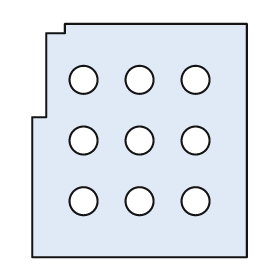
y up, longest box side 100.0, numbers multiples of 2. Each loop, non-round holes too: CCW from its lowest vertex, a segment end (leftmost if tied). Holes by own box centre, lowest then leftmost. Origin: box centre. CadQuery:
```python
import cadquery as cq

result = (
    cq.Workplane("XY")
    .moveTo(-46.0, -50.0)
    .lineTo(46.0, -50.0)
    .lineTo(46.0, 50.0)
    .lineTo(-32.0, 50.0)
    .lineTo(-32.0, 46.0)
    .lineTo(-40.0, 46.0)
    .lineTo(-40.0, 10.0)
    .lineTo(-46.0, 10.0)
    .close()
    .moveTo(-24.0, -26.0)
    .circle(6.0)
    .moveTo(0.0, -26.0)
    .circle(6.0)
    .moveTo(24.0, -26.0)
    .circle(6.0)
    .moveTo(-24.0, 0.0)
    .circle(6.0)
    .moveTo(0.0, 0.0)
    .circle(6.0)
    .moveTo(24.0, 0.0)
    .circle(6.0)
    .moveTo(-24.0, 26.0)
    .circle(6.0)
    .moveTo(0.0, 26.0)
    .circle(6.0)
    .moveTo(24.0, 26.0)
    .circle(6.0)
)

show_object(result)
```